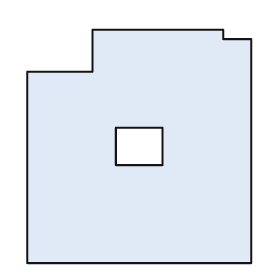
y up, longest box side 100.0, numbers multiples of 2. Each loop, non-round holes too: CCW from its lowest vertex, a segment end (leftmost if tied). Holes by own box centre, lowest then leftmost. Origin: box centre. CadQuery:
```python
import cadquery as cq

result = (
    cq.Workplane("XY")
    .moveTo(-48.0, -50.0)
    .lineTo(48.0, -50.0)
    .lineTo(48.0, 46.0)
    .lineTo(36.0, 46.0)
    .lineTo(36.0, 50.0)
    .lineTo(-20.0, 50.0)
    .lineTo(-20.0, 32.0)
    .lineTo(-48.0, 32.0)
    .close()
    .moveTo(-10.0, -8.0)
    .lineTo(10.0, -8.0)
    .lineTo(10.0, 8.0)
    .lineTo(-10.0, 8.0)
    .close()
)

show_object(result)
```